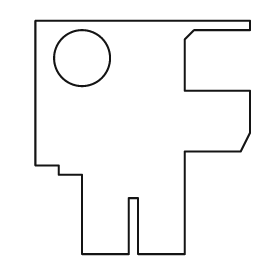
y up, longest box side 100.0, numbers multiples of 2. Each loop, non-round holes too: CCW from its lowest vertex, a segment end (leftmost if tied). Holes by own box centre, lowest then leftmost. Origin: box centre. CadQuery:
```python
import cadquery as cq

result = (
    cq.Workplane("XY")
    .moveTo(-26.0, -50.0)
    .lineTo(-6.0, -50.0)
    .lineTo(-6.0, -26.0)
    .lineTo(-2.0, -26.0)
    .lineTo(-2.0, -50.0)
    .lineTo(18.0, -50.0)
    .lineTo(18.0, -6.0)
    .lineTo(42.0, -6.0)
    .lineTo(46.0, 2.0)
    .lineTo(46.0, 20.0)
    .lineTo(18.0, 20.0)
    .lineTo(18.0, 42.0)
    .lineTo(22.0, 46.0)
    .lineTo(46.0, 46.0)
    .lineTo(46.0, 50.0)
    .lineTo(-46.0, 50.0)
    .lineTo(-46.0, -12.0)
    .lineTo(-36.0, -12.0)
    .lineTo(-36.0, -16.0)
    .lineTo(-26.0, -16.0)
    .close()
    .moveTo(-26.0, 34.0)
    .circle(12.0)
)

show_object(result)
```